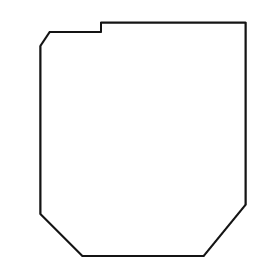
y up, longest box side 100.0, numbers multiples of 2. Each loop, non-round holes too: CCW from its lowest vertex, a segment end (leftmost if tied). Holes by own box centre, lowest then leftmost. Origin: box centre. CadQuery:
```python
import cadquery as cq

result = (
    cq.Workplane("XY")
    .moveTo(-26.0, -50.0)
    .lineTo(26.0, -50.0)
    .lineTo(44.0, -28.0)
    .lineTo(44.0, 50.0)
    .lineTo(-18.0, 50.0)
    .lineTo(-18.0, 46.0)
    .lineTo(-40.0, 46.0)
    .lineTo(-44.0, 40.0)
    .lineTo(-44.0, -32.0)
    .close()
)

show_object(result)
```